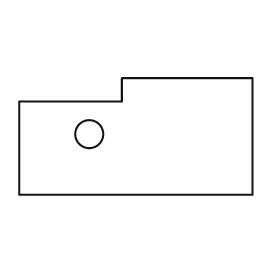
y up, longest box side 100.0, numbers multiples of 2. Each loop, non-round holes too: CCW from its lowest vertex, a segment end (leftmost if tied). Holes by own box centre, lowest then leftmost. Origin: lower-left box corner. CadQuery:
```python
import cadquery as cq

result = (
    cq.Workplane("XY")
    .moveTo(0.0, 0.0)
    .lineTo(100.0, 0.0)
    .lineTo(100.0, 50.0)
    .lineTo(44.0, 50.0)
    .lineTo(44.0, 40.0)
    .lineTo(0.0, 40.0)
    .close()
    .moveTo(30.0, 26.0)
    .circle(6.0)
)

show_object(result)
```